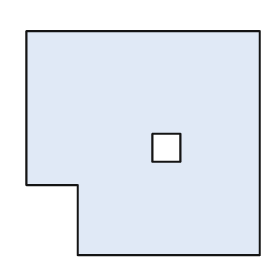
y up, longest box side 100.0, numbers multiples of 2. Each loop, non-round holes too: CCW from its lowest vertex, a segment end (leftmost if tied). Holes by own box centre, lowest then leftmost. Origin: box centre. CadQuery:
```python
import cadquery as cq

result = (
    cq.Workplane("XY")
    .moveTo(-28.0, -48.0)
    .lineTo(50.0, -48.0)
    .lineTo(50.0, 48.0)
    .lineTo(-50.0, 48.0)
    .lineTo(-50.0, -18.0)
    .lineTo(-28.0, -18.0)
    .close()
    .moveTo(4.0, -8.0)
    .lineTo(16.0, -8.0)
    .lineTo(16.0, 4.0)
    .lineTo(4.0, 4.0)
    .close()
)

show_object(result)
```